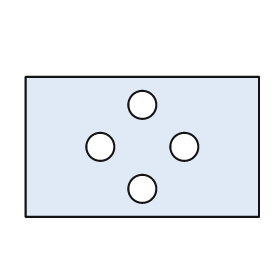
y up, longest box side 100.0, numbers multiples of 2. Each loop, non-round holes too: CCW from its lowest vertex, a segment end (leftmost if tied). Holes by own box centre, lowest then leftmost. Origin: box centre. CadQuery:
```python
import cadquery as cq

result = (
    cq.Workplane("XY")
    .moveTo(-50.0, -30.0)
    .lineTo(50.0, -30.0)
    .lineTo(50.0, 30.0)
    .lineTo(-50.0, 30.0)
    .close()
    .moveTo(0.0, -18.0)
    .circle(6.0)
    .moveTo(-18.0, 0.0)
    .circle(6.0)
    .moveTo(18.0, 0.0)
    .circle(6.0)
    .moveTo(0.0, 18.0)
    .circle(6.0)
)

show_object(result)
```